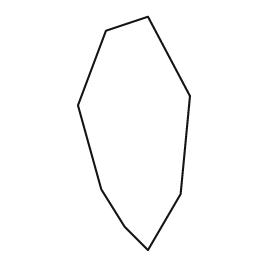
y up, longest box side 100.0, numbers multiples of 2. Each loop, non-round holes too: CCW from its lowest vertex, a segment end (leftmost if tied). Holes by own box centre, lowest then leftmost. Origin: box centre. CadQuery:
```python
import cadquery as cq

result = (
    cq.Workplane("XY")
    .moveTo(6.0, -50.0)
    .lineTo(20.0, -26.0)
    .lineTo(24.0, 16.0)
    .lineTo(6.0, 50.0)
    .lineTo(-12.0, 44.0)
    .lineTo(-24.0, 12.0)
    .lineTo(-14.0, -24.0)
    .lineTo(-4.0, -40.0)
    .close()
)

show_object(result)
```